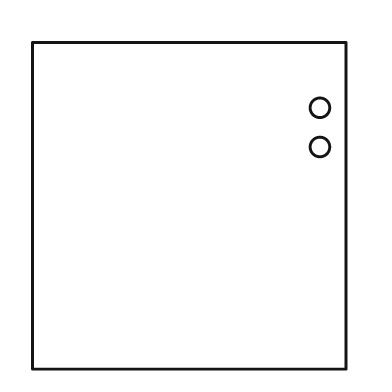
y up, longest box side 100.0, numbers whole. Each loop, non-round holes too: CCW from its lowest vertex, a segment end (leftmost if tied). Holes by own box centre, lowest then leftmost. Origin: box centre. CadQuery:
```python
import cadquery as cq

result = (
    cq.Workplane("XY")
    .moveTo(-48.0, -50.0)
    .lineTo(48.0, -50.0)
    .lineTo(48.0, 50.0)
    .lineTo(-48.0, 50.0)
    .close()
    .moveTo(40.0, 18.0)
    .circle(3.0)
    .moveTo(40.0, 30.0)
    .circle(3.0)
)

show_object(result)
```